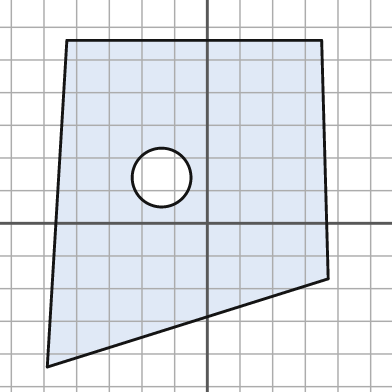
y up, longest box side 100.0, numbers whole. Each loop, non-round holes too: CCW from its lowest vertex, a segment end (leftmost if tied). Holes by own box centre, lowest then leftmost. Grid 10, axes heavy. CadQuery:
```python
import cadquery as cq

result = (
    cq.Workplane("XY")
    .moveTo(-49.0, -44.0)
    .lineTo(37.0, -17.0)
    .lineTo(35.0, 56.0)
    .lineTo(-43.0, 56.0)
    .close()
    .moveTo(-14.0, 14.0)
    .circle(9.0)
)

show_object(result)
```